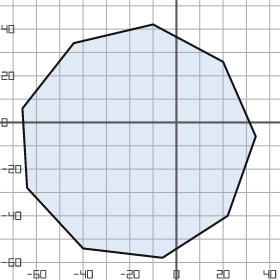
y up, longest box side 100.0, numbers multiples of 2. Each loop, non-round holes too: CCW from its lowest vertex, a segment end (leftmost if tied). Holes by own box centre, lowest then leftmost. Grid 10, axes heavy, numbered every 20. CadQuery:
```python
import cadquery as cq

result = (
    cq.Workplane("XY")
    .moveTo(-6.0, -58.0)
    .lineTo(22.0, -40.0)
    .lineTo(34.0, -6.0)
    .lineTo(20.0, 26.0)
    .lineTo(-10.0, 42.0)
    .lineTo(-44.0, 34.0)
    .lineTo(-66.0, 6.0)
    .lineTo(-64.0, -28.0)
    .lineTo(-40.0, -54.0)
    .close()
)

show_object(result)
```